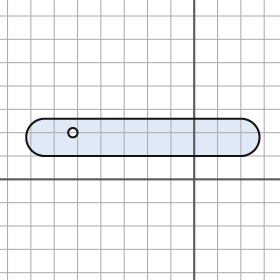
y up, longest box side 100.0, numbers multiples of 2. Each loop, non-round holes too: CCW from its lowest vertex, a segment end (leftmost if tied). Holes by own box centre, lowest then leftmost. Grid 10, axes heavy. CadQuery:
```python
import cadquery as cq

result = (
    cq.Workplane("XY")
    .moveTo(-64.0, 10.0)
    .lineTo(20.0, 10.0)
    .threePointArc((28.0, 18.0), (20.0, 26.0))
    .lineTo(-64.0, 26.0)
    .threePointArc((-72.0, 18.0), (-64.0, 10.0))
    .close()
    .moveTo(-52.0, 20.0)
    .circle(2.0)
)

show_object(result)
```